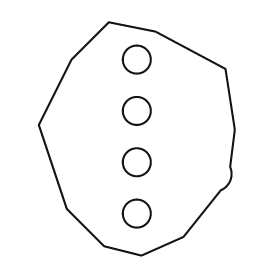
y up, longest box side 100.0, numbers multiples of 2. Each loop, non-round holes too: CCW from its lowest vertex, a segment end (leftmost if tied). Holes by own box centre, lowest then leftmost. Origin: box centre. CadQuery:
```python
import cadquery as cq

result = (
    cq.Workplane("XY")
    .moveTo(2.0, -50.0)
    .lineTo(20.0, -42.0)
    .lineTo(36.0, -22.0)
    .threePointArc((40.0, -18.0), (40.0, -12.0))
    .lineTo(42.0, 4.0)
    .lineTo(38.0, 30.0)
    .lineTo(8.0, 46.0)
    .lineTo(-12.0, 50.0)
    .lineTo(-28.0, 34.0)
    .lineTo(-42.0, 6.0)
    .lineTo(-30.0, -30.0)
    .lineTo(-14.0, -46.0)
    .close()
    .moveTo(0.0, -32.0)
    .circle(6.0)
    .moveTo(0.0, -10.0)
    .circle(6.0)
    .moveTo(0.0, 12.0)
    .circle(6.0)
    .moveTo(0.0, 34.0)
    .circle(6.0)
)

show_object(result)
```